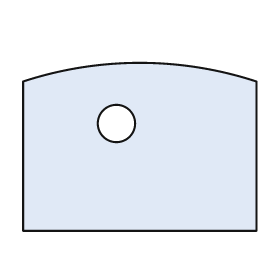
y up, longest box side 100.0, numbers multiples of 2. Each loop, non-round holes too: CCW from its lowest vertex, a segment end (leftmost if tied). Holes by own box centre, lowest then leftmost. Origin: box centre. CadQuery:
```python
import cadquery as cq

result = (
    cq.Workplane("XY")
    .moveTo(-50.0, -36.0)
    .lineTo(50.0, -36.0)
    .lineTo(50.0, 28.0)
    .threePointArc((0.0, 36.0), (-50.0, 28.0))
    .close()
    .moveTo(-10.0, 10.0)
    .circle(8.0)
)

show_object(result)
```